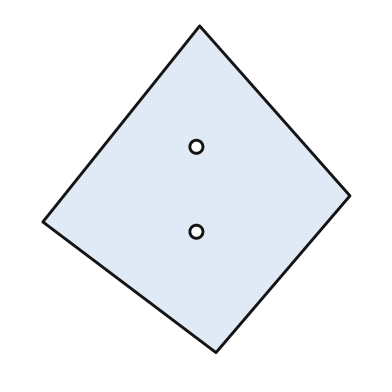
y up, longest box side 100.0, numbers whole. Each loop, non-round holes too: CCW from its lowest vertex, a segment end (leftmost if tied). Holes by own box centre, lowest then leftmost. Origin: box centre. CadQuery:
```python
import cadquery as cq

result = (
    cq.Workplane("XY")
    .moveTo(6.0, -50.0)
    .lineTo(47.0, -2.0)
    .lineTo(1.0, 50.0)
    .lineTo(-47.0, -10.0)
    .close()
    .moveTo(0.0, -13.0)
    .circle(2.0)
    .moveTo(0.0, 13.0)
    .circle(2.0)
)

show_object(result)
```